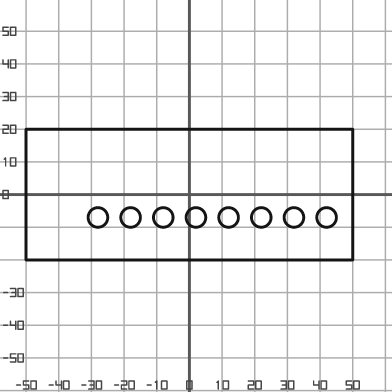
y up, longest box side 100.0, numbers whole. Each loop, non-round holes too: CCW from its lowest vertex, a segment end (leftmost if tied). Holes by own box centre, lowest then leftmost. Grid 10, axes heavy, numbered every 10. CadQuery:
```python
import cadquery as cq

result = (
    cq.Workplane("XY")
    .moveTo(-50.0, -20.0)
    .lineTo(50.0, -20.0)
    .lineTo(50.0, 20.0)
    .lineTo(-50.0, 20.0)
    .close()
    .moveTo(-28.0, -7.0)
    .circle(3.0)
    .moveTo(-18.0, -7.0)
    .circle(3.0)
    .moveTo(-8.0, -7.0)
    .circle(3.0)
    .moveTo(2.0, -7.0)
    .circle(3.0)
    .moveTo(12.0, -7.0)
    .circle(3.0)
    .moveTo(22.0, -7.0)
    .circle(3.0)
    .moveTo(32.0, -7.0)
    .circle(3.0)
    .moveTo(42.0, -7.0)
    .circle(3.0)
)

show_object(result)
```